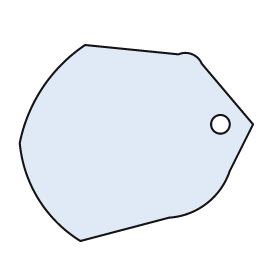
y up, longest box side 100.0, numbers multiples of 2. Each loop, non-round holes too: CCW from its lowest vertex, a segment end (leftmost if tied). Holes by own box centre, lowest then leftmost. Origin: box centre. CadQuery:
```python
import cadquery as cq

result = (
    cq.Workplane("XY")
    .moveTo(-24.0, -42.0)
    .lineTo(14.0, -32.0)
    .threePointArc((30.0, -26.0), (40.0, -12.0))
    .lineTo(50.0, 8.0)
    .lineTo(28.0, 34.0)
    .threePointArc((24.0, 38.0), (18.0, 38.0))
    .lineTo(-22.0, 42.0)
    .threePointArc((-40.0, 24.0), (-50.0, 0.0))
    .threePointArc((-42.0, -24.0), (-24.0, -42.0))
    .close()
    .moveTo(36.0, 8.0)
    .circle(4.0)
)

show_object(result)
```